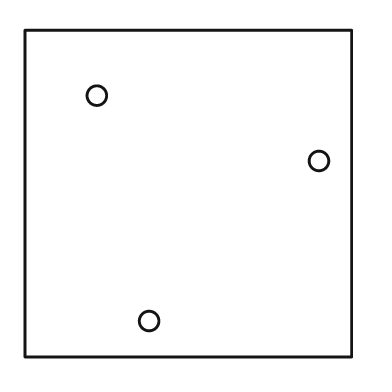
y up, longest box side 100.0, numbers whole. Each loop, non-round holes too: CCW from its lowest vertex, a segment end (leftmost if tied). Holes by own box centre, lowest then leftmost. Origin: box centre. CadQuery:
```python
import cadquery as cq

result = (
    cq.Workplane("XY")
    .moveTo(-50.0, -50.0)
    .lineTo(50.0, -50.0)
    .lineTo(50.0, 50.0)
    .lineTo(-50.0, 50.0)
    .close()
    .moveTo(-12.0, -39.0)
    .circle(3.0)
    .moveTo(40.0, 10.0)
    .circle(3.0)
    .moveTo(-28.0, 30.0)
    .circle(3.0)
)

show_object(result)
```